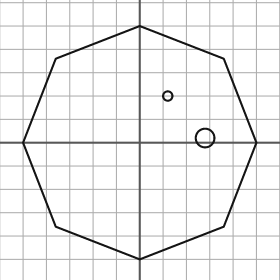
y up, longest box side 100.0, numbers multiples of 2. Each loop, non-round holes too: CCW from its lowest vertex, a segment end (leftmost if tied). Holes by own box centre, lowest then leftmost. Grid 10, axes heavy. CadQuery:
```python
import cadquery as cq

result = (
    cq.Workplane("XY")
    .moveTo(0.0, -50.0)
    .lineTo(36.0, -36.0)
    .lineTo(50.0, 0.0)
    .lineTo(36.0, 36.0)
    .lineTo(0.0, 50.0)
    .lineTo(-36.0, 36.0)
    .lineTo(-50.0, 0.0)
    .lineTo(-36.0, -36.0)
    .close()
    .moveTo(28.0, 2.0)
    .circle(4.0)
    .moveTo(12.0, 20.0)
    .circle(2.0)
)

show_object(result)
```